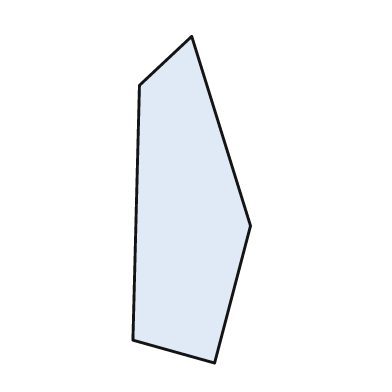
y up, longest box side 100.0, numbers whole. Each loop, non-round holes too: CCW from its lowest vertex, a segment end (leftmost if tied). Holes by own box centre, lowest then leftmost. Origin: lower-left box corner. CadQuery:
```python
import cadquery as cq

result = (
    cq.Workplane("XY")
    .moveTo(25.0, 0.0)
    .lineTo(36.0, 42.0)
    .lineTo(18.0, 100.0)
    .lineTo(2.0, 85.0)
    .lineTo(0.0, 7.0)
    .close()
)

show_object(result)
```